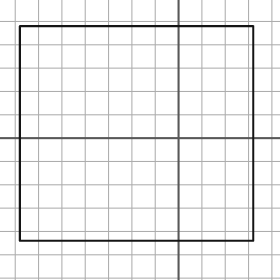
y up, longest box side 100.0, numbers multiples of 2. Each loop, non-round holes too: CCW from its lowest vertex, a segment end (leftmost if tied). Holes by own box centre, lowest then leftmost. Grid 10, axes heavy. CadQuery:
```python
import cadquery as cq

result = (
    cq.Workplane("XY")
    .moveTo(-68.0, -44.0)
    .lineTo(32.0, -44.0)
    .lineTo(32.0, 48.0)
    .lineTo(-68.0, 48.0)
    .close()
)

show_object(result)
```